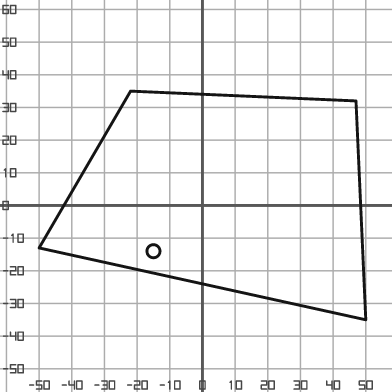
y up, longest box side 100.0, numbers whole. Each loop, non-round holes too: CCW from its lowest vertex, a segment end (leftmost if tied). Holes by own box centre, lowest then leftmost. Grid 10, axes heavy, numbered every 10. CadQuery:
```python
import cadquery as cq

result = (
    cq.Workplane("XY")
    .moveTo(50.0, -35.0)
    .lineTo(47.0, 32.0)
    .lineTo(-22.0, 35.0)
    .lineTo(-50.0, -13.0)
    .close()
    .moveTo(-15.0, -14.0)
    .circle(2.0)
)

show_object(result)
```